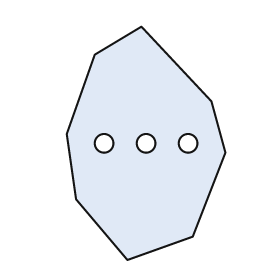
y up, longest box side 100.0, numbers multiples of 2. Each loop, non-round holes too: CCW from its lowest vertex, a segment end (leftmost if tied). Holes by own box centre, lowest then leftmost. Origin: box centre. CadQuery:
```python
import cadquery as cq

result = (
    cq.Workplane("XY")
    .moveTo(-8.0, -50.0)
    .lineTo(20.0, -40.0)
    .lineTo(34.0, -4.0)
    .lineTo(28.0, 18.0)
    .lineTo(-2.0, 50.0)
    .lineTo(-22.0, 38.0)
    .lineTo(-34.0, 4.0)
    .lineTo(-30.0, -24.0)
    .close()
    .moveTo(-18.0, 0.0)
    .circle(4.0)
    .moveTo(0.0, 0.0)
    .circle(4.0)
    .moveTo(18.0, 0.0)
    .circle(4.0)
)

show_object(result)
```